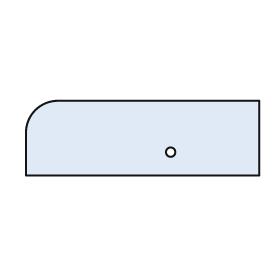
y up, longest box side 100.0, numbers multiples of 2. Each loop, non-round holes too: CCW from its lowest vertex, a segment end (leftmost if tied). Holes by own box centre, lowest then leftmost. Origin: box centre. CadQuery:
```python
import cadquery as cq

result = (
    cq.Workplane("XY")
    .moveTo(-50.0, -16.0)
    .lineTo(50.0, -16.0)
    .lineTo(50.0, 16.0)
    .lineTo(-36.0, 16.0)
    .threePointArc((-46.0, 12.0), (-50.0, 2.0))
    .close()
    .moveTo(12.0, -6.0)
    .circle(2.0)
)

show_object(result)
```